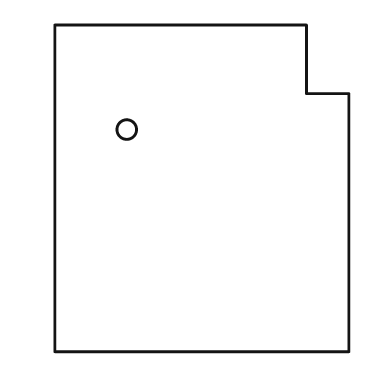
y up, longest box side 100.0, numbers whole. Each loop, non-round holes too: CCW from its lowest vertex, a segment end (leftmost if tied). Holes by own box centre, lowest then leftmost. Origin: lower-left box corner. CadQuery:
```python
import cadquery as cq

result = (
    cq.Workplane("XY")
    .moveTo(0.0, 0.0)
    .lineTo(90.0, 0.0)
    .lineTo(90.0, 79.0)
    .lineTo(77.0, 79.0)
    .lineTo(77.0, 100.0)
    .lineTo(0.0, 100.0)
    .close()
    .moveTo(22.0, 68.0)
    .circle(3.0)
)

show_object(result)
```